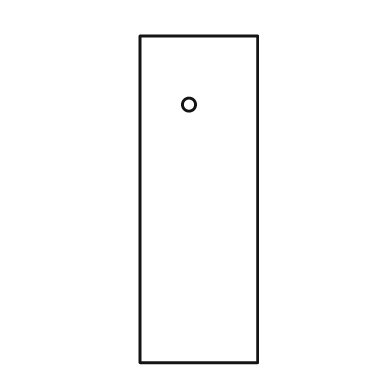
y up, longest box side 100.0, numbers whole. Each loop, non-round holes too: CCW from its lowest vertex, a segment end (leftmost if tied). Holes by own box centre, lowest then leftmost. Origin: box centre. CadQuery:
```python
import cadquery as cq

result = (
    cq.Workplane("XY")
    .moveTo(-18.0, -50.0)
    .lineTo(18.0, -50.0)
    .lineTo(18.0, 50.0)
    .lineTo(-18.0, 50.0)
    .close()
    .moveTo(-3.0, 29.0)
    .circle(2.0)
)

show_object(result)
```